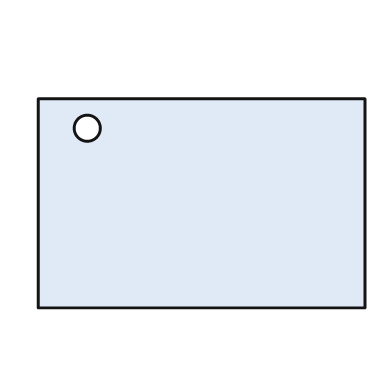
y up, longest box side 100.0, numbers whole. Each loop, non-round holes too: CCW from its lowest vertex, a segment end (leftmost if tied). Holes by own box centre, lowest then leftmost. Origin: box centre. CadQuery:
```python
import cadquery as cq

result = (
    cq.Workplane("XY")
    .moveTo(-50.0, -32.0)
    .lineTo(50.0, -32.0)
    .lineTo(50.0, 32.0)
    .lineTo(-50.0, 32.0)
    .close()
    .moveTo(-35.0, 23.0)
    .circle(4.0)
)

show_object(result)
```